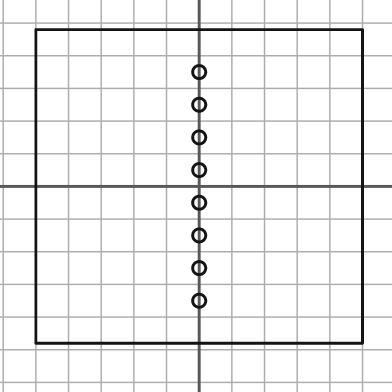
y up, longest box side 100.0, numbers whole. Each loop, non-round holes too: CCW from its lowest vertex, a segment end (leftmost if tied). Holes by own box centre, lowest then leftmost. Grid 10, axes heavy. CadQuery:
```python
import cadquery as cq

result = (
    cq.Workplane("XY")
    .moveTo(-50.0, -48.0)
    .lineTo(50.0, -48.0)
    .lineTo(50.0, 48.0)
    .lineTo(-50.0, 48.0)
    .close()
    .moveTo(0.0, -35.0)
    .circle(2.0)
    .moveTo(0.0, -25.0)
    .circle(2.0)
    .moveTo(0.0, -15.0)
    .circle(2.0)
    .moveTo(0.0, -5.0)
    .circle(2.0)
    .moveTo(0.0, 5.0)
    .circle(2.0)
    .moveTo(0.0, 15.0)
    .circle(2.0)
    .moveTo(0.0, 25.0)
    .circle(2.0)
    .moveTo(0.0, 35.0)
    .circle(2.0)
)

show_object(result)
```